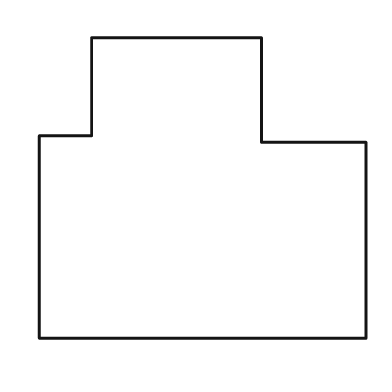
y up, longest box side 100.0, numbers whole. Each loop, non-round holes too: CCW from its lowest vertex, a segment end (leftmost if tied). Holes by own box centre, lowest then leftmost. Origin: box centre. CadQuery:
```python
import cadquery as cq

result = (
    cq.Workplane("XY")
    .moveTo(-50.0, -46.0)
    .lineTo(50.0, -46.0)
    .lineTo(50.0, 14.0)
    .lineTo(18.0, 14.0)
    .lineTo(18.0, 46.0)
    .lineTo(-34.0, 46.0)
    .lineTo(-34.0, 16.0)
    .lineTo(-50.0, 16.0)
    .close()
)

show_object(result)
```